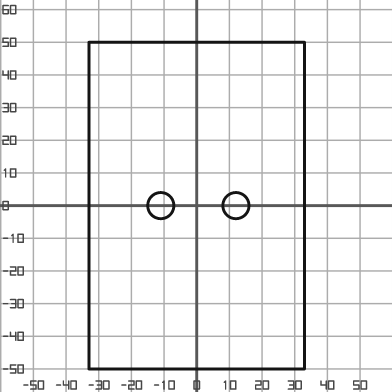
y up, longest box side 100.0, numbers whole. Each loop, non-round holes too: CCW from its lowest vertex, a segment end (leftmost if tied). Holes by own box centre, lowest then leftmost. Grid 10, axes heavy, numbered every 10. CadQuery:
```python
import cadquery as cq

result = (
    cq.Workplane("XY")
    .moveTo(-33.0, -50.0)
    .lineTo(33.0, -50.0)
    .lineTo(33.0, 50.0)
    .lineTo(-33.0, 50.0)
    .close()
    .moveTo(-11.0, 0.0)
    .circle(4.0)
    .moveTo(12.0, 0.0)
    .circle(4.0)
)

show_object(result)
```